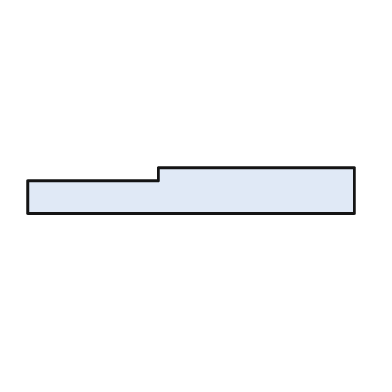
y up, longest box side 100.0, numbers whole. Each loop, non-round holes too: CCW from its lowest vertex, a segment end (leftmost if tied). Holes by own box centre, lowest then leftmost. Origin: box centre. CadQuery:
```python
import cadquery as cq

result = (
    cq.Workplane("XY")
    .moveTo(-50.0, -7.0)
    .lineTo(50.0, -7.0)
    .lineTo(50.0, 7.0)
    .lineTo(-10.0, 7.0)
    .lineTo(-10.0, 3.0)
    .lineTo(-50.0, 3.0)
    .close()
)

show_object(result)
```